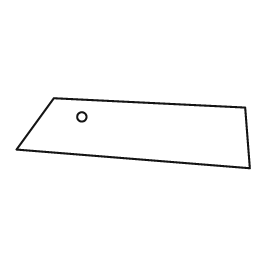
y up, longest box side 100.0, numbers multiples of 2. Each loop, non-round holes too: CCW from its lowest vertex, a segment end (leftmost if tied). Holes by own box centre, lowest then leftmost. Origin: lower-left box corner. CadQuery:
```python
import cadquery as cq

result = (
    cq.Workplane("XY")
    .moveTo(100.0, 0.0)
    .lineTo(98.0, 26.0)
    .lineTo(16.0, 30.0)
    .lineTo(0.0, 8.0)
    .close()
    .moveTo(28.0, 22.0)
    .circle(2.0)
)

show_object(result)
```